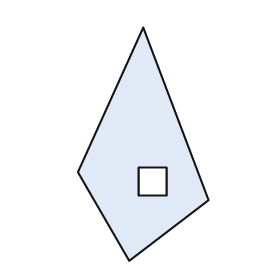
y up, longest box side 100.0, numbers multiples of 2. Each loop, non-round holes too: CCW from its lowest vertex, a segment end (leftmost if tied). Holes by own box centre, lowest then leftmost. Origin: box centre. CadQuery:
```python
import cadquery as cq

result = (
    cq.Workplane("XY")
    .moveTo(-6.0, -50.0)
    .lineTo(28.0, -24.0)
    .lineTo(0.0, 50.0)
    .lineTo(-28.0, -12.0)
    .close()
    .moveTo(-2.0, -22.0)
    .lineTo(10.0, -22.0)
    .lineTo(10.0, -10.0)
    .lineTo(-2.0, -10.0)
    .close()
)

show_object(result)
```